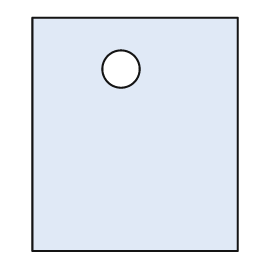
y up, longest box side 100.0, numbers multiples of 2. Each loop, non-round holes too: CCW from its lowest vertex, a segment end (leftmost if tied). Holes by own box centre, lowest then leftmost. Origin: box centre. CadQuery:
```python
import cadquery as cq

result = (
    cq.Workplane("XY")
    .moveTo(-44.0, -50.0)
    .lineTo(44.0, -50.0)
    .lineTo(44.0, 50.0)
    .lineTo(-44.0, 50.0)
    .close()
    .moveTo(-6.0, 28.0)
    .circle(8.0)
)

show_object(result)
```